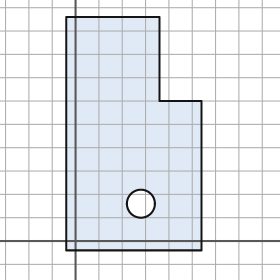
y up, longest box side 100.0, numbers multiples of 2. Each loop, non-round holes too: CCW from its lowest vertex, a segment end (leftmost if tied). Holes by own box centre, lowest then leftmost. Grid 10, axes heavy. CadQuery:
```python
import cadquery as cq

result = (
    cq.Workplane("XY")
    .moveTo(-4.0, -4.0)
    .lineTo(54.0, -4.0)
    .lineTo(54.0, 60.0)
    .lineTo(36.0, 60.0)
    .lineTo(36.0, 96.0)
    .lineTo(-4.0, 96.0)
    .close()
    .moveTo(28.0, 16.0)
    .circle(6.0)
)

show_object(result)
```